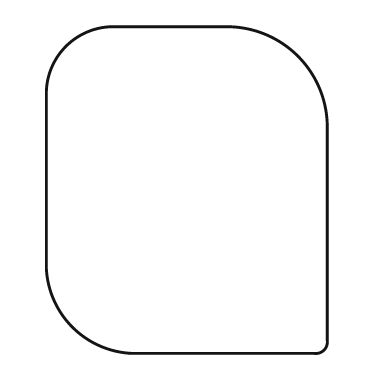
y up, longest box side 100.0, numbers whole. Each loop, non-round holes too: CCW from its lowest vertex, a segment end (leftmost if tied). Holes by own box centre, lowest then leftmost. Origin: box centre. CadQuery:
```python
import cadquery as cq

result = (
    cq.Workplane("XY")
    .moveTo(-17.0, -50.0)
    .lineTo(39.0, -50.0)
    .threePointArc((42.0, -49.0), (43.0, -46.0))
    .lineTo(43.0, 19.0)
    .threePointArc((34.0, 41.0), (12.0, 50.0))
    .lineTo(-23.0, 50.0)
    .threePointArc((-37.0, 44.0), (-43.0, 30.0))
    .lineTo(-43.0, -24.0)
    .threePointArc((-35.0, -42.0), (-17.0, -50.0))
    .close()
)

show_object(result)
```